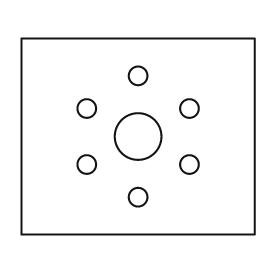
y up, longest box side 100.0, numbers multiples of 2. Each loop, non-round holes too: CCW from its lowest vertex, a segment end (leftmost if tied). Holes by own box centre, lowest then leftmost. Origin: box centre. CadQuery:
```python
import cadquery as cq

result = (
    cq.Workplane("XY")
    .moveTo(-50.0, -42.0)
    .lineTo(50.0, -42.0)
    .lineTo(50.0, 42.0)
    .lineTo(-50.0, 42.0)
    .close()
    .moveTo(0.0, -26.0)
    .circle(4.0)
    .moveTo(-22.0, -12.0)
    .circle(4.0)
    .moveTo(22.0, -12.0)
    .circle(4.0)
    .moveTo(0.0, 0.0)
    .circle(10.0)
    .moveTo(-22.0, 12.0)
    .circle(4.0)
    .moveTo(22.0, 12.0)
    .circle(4.0)
    .moveTo(0.0, 26.0)
    .circle(4.0)
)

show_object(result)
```